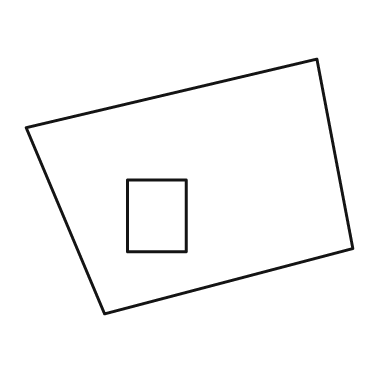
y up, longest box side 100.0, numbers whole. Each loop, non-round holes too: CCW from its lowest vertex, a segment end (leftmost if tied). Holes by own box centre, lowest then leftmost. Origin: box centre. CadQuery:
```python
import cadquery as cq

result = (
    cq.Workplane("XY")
    .moveTo(-26.0, -39.0)
    .lineTo(50.0, -19.0)
    .lineTo(39.0, 39.0)
    .lineTo(-50.0, 18.0)
    .close()
    .moveTo(-19.0, -20.0)
    .lineTo(-1.0, -20.0)
    .lineTo(-1.0, 2.0)
    .lineTo(-19.0, 2.0)
    .close()
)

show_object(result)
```